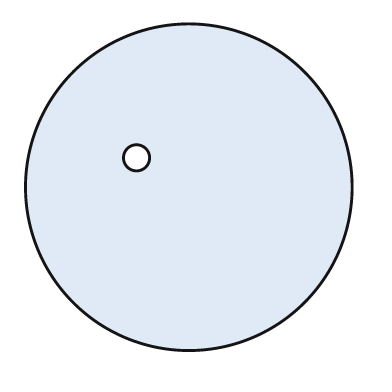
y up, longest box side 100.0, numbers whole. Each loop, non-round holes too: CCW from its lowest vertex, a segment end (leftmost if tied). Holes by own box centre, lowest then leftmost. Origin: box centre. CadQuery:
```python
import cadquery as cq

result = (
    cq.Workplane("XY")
    .moveTo(0.0, 0.0)
    .circle(50.0)
    .moveTo(-16.0, 9.0)
    .circle(4.0)
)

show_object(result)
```